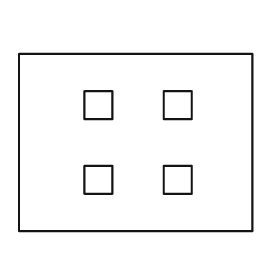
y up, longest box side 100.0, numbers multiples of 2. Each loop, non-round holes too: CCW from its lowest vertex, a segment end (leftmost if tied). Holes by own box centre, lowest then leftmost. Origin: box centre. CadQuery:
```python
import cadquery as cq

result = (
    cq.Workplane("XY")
    .moveTo(-50.0, -38.0)
    .lineTo(50.0, -38.0)
    .lineTo(50.0, 38.0)
    .lineTo(-50.0, 38.0)
    .close()
    .moveTo(-22.0, -22.0)
    .lineTo(-10.0, -22.0)
    .lineTo(-10.0, -10.0)
    .lineTo(-22.0, -10.0)
    .close()
    .moveTo(12.0, -22.0)
    .lineTo(24.0, -22.0)
    .lineTo(24.0, -10.0)
    .lineTo(12.0, -10.0)
    .close()
    .moveTo(-22.0, 10.0)
    .lineTo(-10.0, 10.0)
    .lineTo(-10.0, 22.0)
    .lineTo(-22.0, 22.0)
    .close()
    .moveTo(12.0, 10.0)
    .lineTo(24.0, 10.0)
    .lineTo(24.0, 22.0)
    .lineTo(12.0, 22.0)
    .close()
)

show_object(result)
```